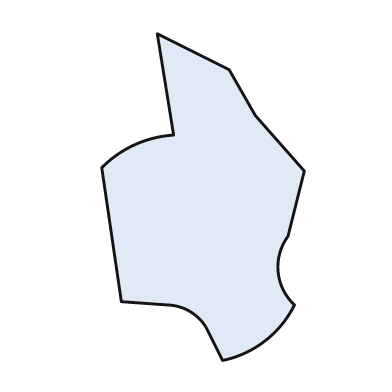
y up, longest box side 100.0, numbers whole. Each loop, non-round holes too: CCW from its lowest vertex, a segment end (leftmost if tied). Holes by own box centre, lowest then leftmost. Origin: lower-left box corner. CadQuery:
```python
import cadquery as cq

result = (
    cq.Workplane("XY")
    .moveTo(37.0, 0.0)
    .threePointArc((50.0, 6.0), (59.0, 17.0))
    .threePointArc((54.0, 27.0), (57.0, 38.0))
    .lineTo(62.0, 58.0)
    .lineTo(47.0, 75.0)
    .lineTo(39.0, 89.0)
    .lineTo(17.0, 100.0)
    .lineTo(22.0, 69.0)
    .threePointArc((10.0, 66.0), (0.0, 59.0))
    .lineTo(6.0, 18.0)
    .lineTo(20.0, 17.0)
    .threePointArc((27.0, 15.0), (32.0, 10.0))
    .close()
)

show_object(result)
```